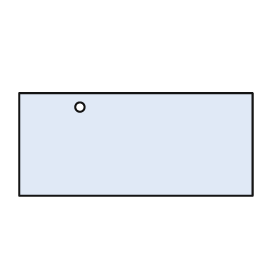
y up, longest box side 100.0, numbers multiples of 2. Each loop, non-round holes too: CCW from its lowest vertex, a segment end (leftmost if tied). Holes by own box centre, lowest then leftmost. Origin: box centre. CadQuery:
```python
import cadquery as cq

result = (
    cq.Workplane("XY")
    .moveTo(-50.0, -22.0)
    .lineTo(50.0, -22.0)
    .lineTo(50.0, 22.0)
    .lineTo(-50.0, 22.0)
    .close()
    .moveTo(-24.0, 16.0)
    .circle(2.0)
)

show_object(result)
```